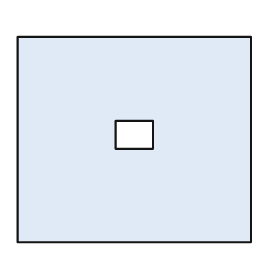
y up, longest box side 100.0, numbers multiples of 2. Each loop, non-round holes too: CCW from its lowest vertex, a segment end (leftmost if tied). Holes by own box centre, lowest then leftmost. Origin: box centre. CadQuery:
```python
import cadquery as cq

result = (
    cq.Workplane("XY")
    .moveTo(-50.0, -44.0)
    .lineTo(50.0, -44.0)
    .lineTo(50.0, 44.0)
    .lineTo(-50.0, 44.0)
    .close()
    .moveTo(-8.0, -4.0)
    .lineTo(8.0, -4.0)
    .lineTo(8.0, 8.0)
    .lineTo(-8.0, 8.0)
    .close()
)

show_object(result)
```